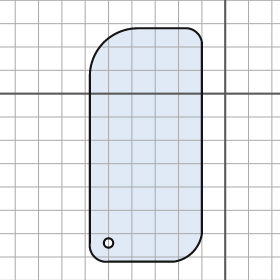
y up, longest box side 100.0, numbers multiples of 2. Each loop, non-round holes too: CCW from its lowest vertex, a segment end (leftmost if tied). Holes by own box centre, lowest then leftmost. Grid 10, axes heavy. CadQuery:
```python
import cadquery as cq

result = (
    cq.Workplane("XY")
    .moveTo(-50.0, -72.0)
    .lineTo(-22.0, -72.0)
    .threePointArc((-14.0, -68.0), (-10.0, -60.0))
    .lineTo(-10.0, 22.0)
    .threePointArc((-12.0, 26.0), (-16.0, 28.0))
    .lineTo(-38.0, 28.0)
    .threePointArc((-52.0, 22.0), (-58.0, 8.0))
    .lineTo(-58.0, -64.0)
    .threePointArc((-56.0, -70.0), (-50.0, -72.0))
    .close()
    .moveTo(-50.0, -64.0)
    .circle(2.0)
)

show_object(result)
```